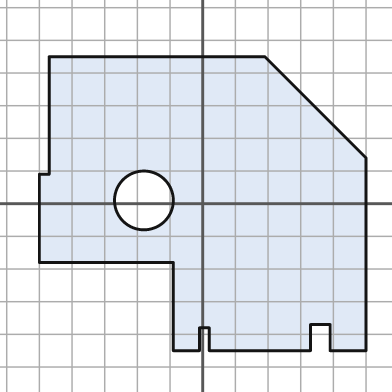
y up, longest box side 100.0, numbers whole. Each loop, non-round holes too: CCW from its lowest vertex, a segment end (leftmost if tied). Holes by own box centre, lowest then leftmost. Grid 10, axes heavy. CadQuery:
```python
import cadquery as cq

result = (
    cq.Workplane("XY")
    .moveTo(-9.0, -45.0)
    .lineTo(-1.0, -45.0)
    .lineTo(-1.0, -38.0)
    .lineTo(2.0, -38.0)
    .lineTo(2.0, -45.0)
    .lineTo(33.0, -45.0)
    .lineTo(33.0, -37.0)
    .lineTo(39.0, -37.0)
    .lineTo(39.0, -45.0)
    .lineTo(50.0, -45.0)
    .lineTo(50.0, 14.0)
    .lineTo(19.0, 45.0)
    .lineTo(-47.0, 45.0)
    .lineTo(-47.0, 9.0)
    .lineTo(-50.0, 9.0)
    .lineTo(-50.0, -18.0)
    .lineTo(-9.0, -18.0)
    .close()
    .moveTo(-18.0, 1.0)
    .circle(9.0)
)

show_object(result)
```